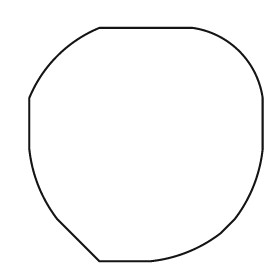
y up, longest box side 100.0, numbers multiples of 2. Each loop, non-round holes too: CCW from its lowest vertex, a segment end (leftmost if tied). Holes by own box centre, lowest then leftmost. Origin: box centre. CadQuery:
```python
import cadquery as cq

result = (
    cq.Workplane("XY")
    .moveTo(-20.0, -50.0)
    .lineTo(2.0, -50.0)
    .threePointArc((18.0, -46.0), (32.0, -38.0))
    .lineTo(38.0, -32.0)
    .threePointArc((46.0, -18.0), (50.0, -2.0))
    .lineTo(50.0, 20.0)
    .threePointArc((40.0, 40.0), (20.0, 50.0))
    .lineTo(-20.0, 50.0)
    .threePointArc((-38.0, 38.0), (-50.0, 20.0))
    .lineTo(-50.0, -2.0)
    .threePointArc((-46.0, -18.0), (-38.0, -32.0))
    .close()
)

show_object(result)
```